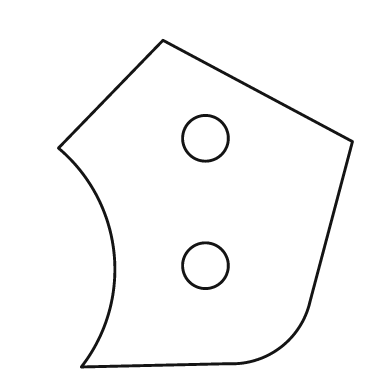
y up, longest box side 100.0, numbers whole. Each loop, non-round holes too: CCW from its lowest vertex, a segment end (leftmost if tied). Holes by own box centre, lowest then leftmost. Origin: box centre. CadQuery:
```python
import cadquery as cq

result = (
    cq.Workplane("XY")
    .moveTo(-38.0, -50.0)
    .lineTo(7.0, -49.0)
    .threePointArc((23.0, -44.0), (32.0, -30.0))
    .lineTo(45.0, 19.0)
    .lineTo(-13.0, 50.0)
    .lineTo(-45.0, 17.0)
    .threePointArc((-28.0, -15.0), (-38.0, -50.0))
    .close()
    .moveTo(0.0, -19.0)
    .circle(7.0)
    .moveTo(0.0, 20.0)
    .circle(7.0)
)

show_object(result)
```